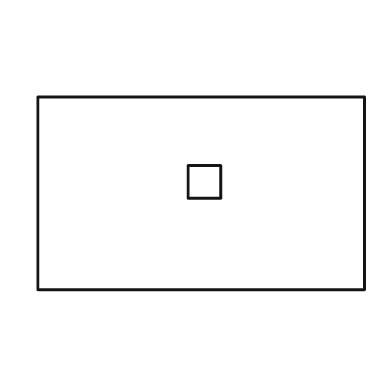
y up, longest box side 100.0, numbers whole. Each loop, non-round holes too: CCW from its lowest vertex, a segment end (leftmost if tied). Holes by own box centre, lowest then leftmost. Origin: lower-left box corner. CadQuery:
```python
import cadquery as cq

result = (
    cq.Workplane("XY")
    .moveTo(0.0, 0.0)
    .lineTo(100.0, 0.0)
    .lineTo(100.0, 59.0)
    .lineTo(0.0, 59.0)
    .close()
    .moveTo(46.0, 28.0)
    .lineTo(56.0, 28.0)
    .lineTo(56.0, 38.0)
    .lineTo(46.0, 38.0)
    .close()
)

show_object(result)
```